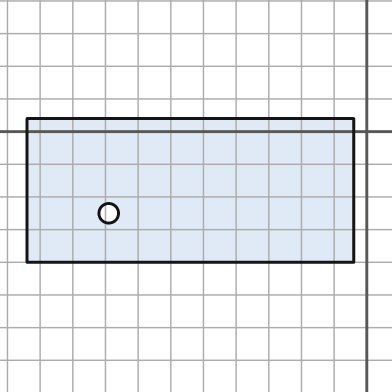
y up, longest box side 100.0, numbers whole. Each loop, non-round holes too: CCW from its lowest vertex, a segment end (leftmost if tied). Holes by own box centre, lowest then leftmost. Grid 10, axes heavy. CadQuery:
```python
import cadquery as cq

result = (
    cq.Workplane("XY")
    .moveTo(-104.0, -40.0)
    .lineTo(-4.0, -40.0)
    .lineTo(-4.0, 4.0)
    .lineTo(-104.0, 4.0)
    .close()
    .moveTo(-79.0, -25.0)
    .circle(3.0)
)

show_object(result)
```